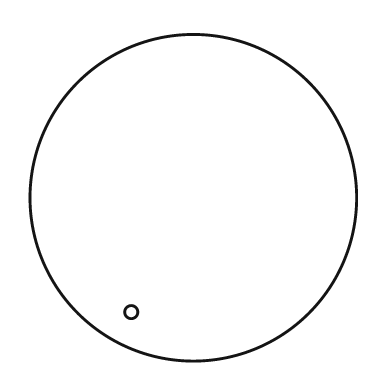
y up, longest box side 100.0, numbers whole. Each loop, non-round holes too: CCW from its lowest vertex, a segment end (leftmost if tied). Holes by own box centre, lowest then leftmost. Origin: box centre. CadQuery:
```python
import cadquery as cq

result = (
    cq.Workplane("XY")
    .moveTo(0.0, 0.0)
    .circle(50.0)
    .moveTo(-19.0, -35.0)
    .circle(2.0)
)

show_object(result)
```